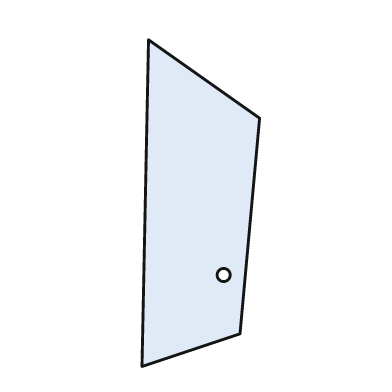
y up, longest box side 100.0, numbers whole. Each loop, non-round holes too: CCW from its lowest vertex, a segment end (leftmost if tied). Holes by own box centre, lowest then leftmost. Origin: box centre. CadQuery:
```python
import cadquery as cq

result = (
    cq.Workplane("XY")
    .moveTo(-18.0, -50.0)
    .lineTo(12.0, -40.0)
    .lineTo(18.0, 26.0)
    .lineTo(-16.0, 50.0)
    .close()
    .moveTo(7.0, -22.0)
    .circle(2.0)
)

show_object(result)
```